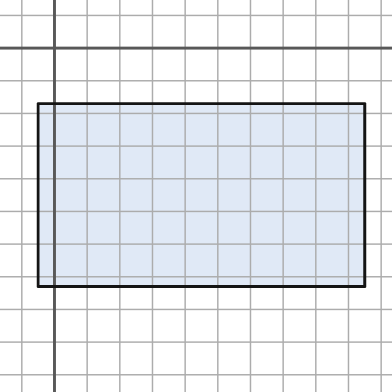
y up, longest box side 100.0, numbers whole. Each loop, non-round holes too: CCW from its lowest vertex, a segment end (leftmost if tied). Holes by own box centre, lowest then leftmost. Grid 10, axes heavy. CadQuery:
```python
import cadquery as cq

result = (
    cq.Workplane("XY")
    .moveTo(-5.0, -73.0)
    .lineTo(95.0, -73.0)
    .lineTo(95.0, -17.0)
    .lineTo(-5.0, -17.0)
    .close()
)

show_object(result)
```